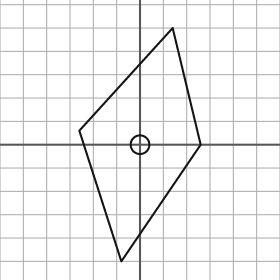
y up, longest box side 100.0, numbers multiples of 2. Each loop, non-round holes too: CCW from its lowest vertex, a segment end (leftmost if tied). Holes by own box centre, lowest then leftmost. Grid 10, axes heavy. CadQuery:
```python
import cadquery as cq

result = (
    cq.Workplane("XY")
    .moveTo(-8.0, -50.0)
    .lineTo(26.0, 0.0)
    .lineTo(14.0, 50.0)
    .lineTo(-26.0, 6.0)
    .close()
    .moveTo(0.0, 0.0)
    .circle(4.0)
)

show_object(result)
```